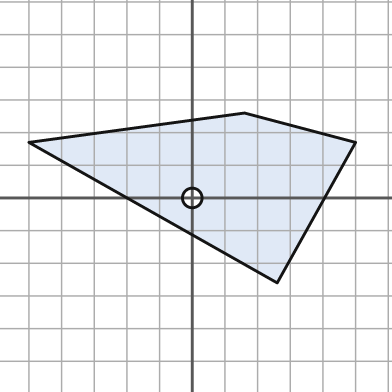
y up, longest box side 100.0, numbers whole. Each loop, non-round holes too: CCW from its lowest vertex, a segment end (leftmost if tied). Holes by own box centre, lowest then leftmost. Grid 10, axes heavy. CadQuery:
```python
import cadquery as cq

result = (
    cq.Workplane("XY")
    .moveTo(26.0, -26.0)
    .lineTo(50.0, 17.0)
    .lineTo(16.0, 26.0)
    .lineTo(-50.0, 17.0)
    .close()
    .moveTo(0.0, 0.0)
    .circle(3.0)
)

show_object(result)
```